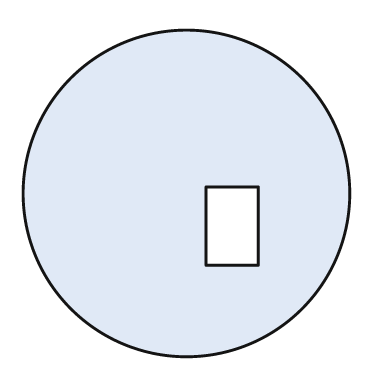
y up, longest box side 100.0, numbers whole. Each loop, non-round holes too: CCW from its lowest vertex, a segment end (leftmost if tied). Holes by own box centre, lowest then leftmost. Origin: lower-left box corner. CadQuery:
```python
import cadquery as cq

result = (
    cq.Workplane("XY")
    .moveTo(50.0, 50.0)
    .circle(50.0)
    .moveTo(56.0, 28.0)
    .lineTo(72.0, 28.0)
    .lineTo(72.0, 52.0)
    .lineTo(56.0, 52.0)
    .close()
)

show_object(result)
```